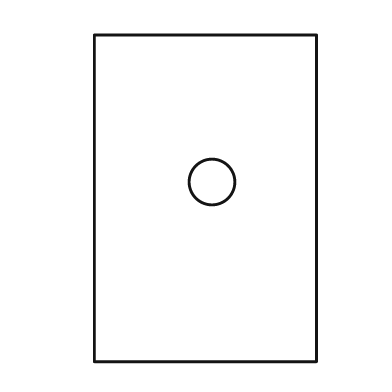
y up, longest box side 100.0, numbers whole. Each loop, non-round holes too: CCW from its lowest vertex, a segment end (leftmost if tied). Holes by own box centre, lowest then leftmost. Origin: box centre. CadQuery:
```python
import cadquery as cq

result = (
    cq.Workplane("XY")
    .moveTo(-34.0, -50.0)
    .lineTo(34.0, -50.0)
    .lineTo(34.0, 50.0)
    .lineTo(-34.0, 50.0)
    .close()
    .moveTo(2.0, 5.0)
    .circle(7.0)
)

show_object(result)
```